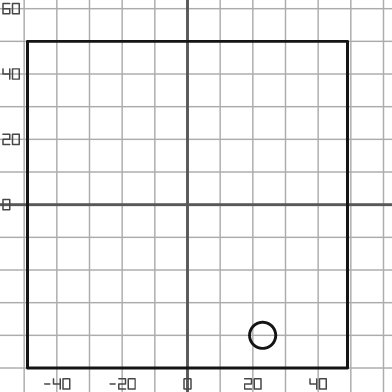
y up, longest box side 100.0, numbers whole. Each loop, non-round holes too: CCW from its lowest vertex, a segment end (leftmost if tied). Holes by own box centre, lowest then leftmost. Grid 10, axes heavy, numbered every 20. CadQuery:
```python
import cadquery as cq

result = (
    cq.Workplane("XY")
    .moveTo(-49.0, -50.0)
    .lineTo(49.0, -50.0)
    .lineTo(49.0, 50.0)
    .lineTo(-49.0, 50.0)
    .close()
    .moveTo(23.0, -40.0)
    .circle(4.0)
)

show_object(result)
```